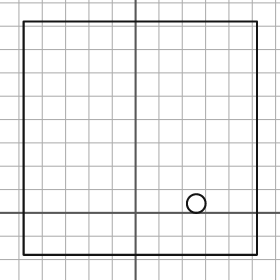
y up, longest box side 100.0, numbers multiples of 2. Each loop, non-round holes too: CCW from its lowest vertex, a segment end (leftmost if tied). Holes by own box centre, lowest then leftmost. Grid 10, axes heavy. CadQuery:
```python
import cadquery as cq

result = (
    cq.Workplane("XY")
    .moveTo(-48.0, -18.0)
    .lineTo(52.0, -18.0)
    .lineTo(52.0, 82.0)
    .lineTo(-48.0, 82.0)
    .close()
    .moveTo(26.0, 4.0)
    .circle(4.0)
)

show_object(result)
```